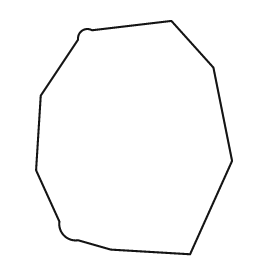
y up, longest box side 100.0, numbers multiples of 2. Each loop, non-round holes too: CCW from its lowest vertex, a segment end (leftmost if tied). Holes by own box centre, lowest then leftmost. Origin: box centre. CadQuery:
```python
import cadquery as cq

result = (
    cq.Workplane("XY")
    .moveTo(24.0, -50.0)
    .lineTo(42.0, -10.0)
    .lineTo(34.0, 30.0)
    .lineTo(16.0, 50.0)
    .lineTo(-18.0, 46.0)
    .threePointArc((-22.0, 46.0), (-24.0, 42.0))
    .lineTo(-40.0, 18.0)
    .lineTo(-42.0, -14.0)
    .lineTo(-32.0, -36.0)
    .threePointArc((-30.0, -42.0), (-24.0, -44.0))
    .lineTo(-10.0, -48.0)
    .close()
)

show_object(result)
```